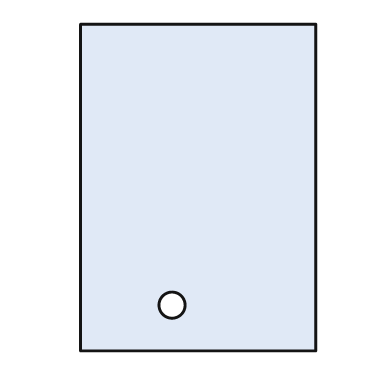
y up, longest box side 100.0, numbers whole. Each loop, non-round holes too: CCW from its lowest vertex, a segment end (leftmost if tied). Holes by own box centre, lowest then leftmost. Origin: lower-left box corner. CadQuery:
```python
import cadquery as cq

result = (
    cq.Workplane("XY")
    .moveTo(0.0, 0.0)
    .lineTo(72.0, 0.0)
    .lineTo(72.0, 100.0)
    .lineTo(0.0, 100.0)
    .close()
    .moveTo(28.0, 14.0)
    .circle(4.0)
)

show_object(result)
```